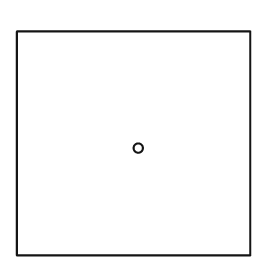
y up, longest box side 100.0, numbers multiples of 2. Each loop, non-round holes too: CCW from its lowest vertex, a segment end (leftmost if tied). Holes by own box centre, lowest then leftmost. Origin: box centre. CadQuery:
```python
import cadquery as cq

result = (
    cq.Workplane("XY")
    .moveTo(-50.0, -48.0)
    .lineTo(50.0, -48.0)
    .lineTo(50.0, 48.0)
    .lineTo(-50.0, 48.0)
    .close()
    .moveTo(2.0, -2.0)
    .circle(2.0)
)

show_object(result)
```